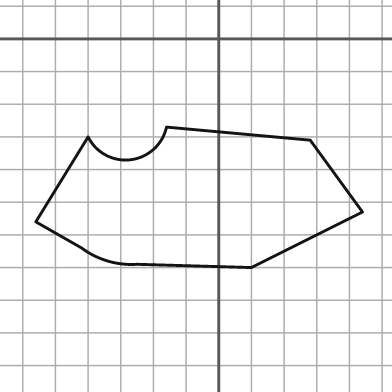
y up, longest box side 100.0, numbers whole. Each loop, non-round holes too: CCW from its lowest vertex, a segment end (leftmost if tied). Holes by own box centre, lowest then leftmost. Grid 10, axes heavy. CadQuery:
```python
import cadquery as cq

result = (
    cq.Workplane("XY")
    .moveTo(10.0, -70.0)
    .lineTo(44.0, -53.0)
    .lineTo(28.0, -31.0)
    .lineTo(-16.0, -27.0)
    .threePointArc((-27.0, -37.0), (-40.0, -30.0))
    .lineTo(-56.0, -56.0)
    .lineTo(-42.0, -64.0)
    .threePointArc((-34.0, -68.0), (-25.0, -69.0))
    .close()
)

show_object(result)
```